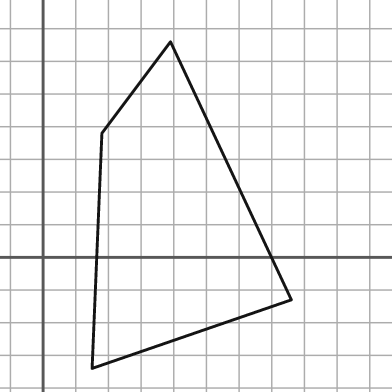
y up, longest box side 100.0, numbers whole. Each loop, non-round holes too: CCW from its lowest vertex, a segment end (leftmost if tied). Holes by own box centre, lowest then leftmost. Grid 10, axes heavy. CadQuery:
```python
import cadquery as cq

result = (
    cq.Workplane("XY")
    .moveTo(15.0, -34.0)
    .lineTo(76.0, -13.0)
    .lineTo(39.0, 66.0)
    .lineTo(18.0, 38.0)
    .close()
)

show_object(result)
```